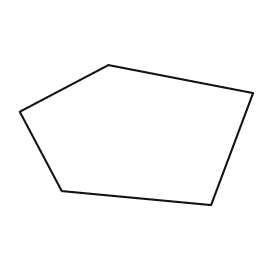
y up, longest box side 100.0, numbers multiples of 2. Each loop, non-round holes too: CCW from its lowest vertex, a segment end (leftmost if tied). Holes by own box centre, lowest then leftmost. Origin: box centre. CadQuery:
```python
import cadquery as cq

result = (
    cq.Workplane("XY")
    .moveTo(32.0, -30.0)
    .lineTo(50.0, 18.0)
    .lineTo(-12.0, 30.0)
    .lineTo(-50.0, 10.0)
    .lineTo(-32.0, -24.0)
    .close()
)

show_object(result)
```